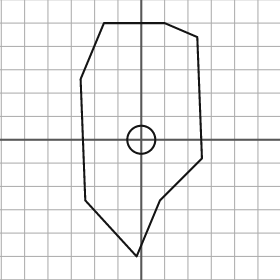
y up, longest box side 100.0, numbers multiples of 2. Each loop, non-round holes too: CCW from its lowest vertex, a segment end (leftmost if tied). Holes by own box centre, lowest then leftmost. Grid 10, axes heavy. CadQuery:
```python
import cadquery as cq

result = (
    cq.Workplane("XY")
    .moveTo(-2.0, -50.0)
    .lineTo(8.0, -26.0)
    .lineTo(26.0, -8.0)
    .lineTo(24.0, 44.0)
    .lineTo(10.0, 50.0)
    .lineTo(-16.0, 50.0)
    .lineTo(-26.0, 26.0)
    .lineTo(-24.0, -26.0)
    .close()
    .moveTo(0.0, 0.0)
    .circle(6.0)
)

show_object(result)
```